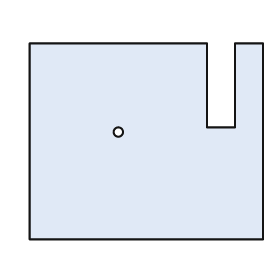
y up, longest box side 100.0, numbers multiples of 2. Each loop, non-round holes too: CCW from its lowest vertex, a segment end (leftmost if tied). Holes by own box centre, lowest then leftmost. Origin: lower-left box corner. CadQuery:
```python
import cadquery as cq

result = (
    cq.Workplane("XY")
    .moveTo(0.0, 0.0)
    .lineTo(100.0, 0.0)
    .lineTo(100.0, 84.0)
    .lineTo(88.0, 84.0)
    .lineTo(88.0, 48.0)
    .lineTo(76.0, 48.0)
    .lineTo(76.0, 84.0)
    .lineTo(0.0, 84.0)
    .close()
    .moveTo(38.0, 46.0)
    .circle(2.0)
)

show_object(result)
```